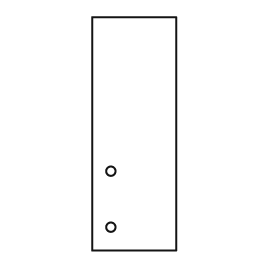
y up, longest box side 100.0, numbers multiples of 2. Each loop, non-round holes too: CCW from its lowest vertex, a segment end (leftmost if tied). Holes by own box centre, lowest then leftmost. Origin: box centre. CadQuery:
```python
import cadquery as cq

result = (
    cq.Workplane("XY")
    .moveTo(-18.0, -50.0)
    .lineTo(18.0, -50.0)
    .lineTo(18.0, 50.0)
    .lineTo(-18.0, 50.0)
    .close()
    .moveTo(-10.0, -40.0)
    .circle(2.0)
    .moveTo(-10.0, -16.0)
    .circle(2.0)
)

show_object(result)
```